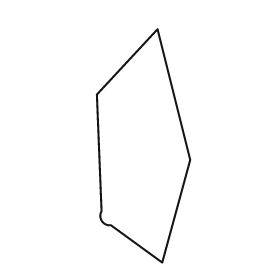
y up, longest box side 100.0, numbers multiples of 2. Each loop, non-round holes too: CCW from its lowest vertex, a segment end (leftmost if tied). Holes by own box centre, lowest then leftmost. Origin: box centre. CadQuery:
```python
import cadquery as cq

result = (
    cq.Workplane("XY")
    .moveTo(8.0, -50.0)
    .lineTo(20.0, -6.0)
    .lineTo(6.0, 50.0)
    .lineTo(-20.0, 22.0)
    .lineTo(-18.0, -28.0)
    .threePointArc((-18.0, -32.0), (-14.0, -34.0))
    .close()
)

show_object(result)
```